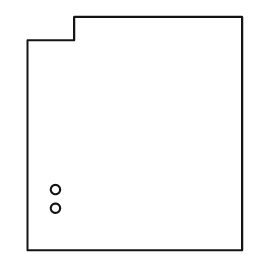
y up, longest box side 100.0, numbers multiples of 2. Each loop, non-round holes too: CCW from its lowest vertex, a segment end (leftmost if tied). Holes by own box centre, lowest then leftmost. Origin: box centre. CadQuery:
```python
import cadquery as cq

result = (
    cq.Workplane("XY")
    .moveTo(-46.0, -50.0)
    .lineTo(46.0, -50.0)
    .lineTo(46.0, 50.0)
    .lineTo(-26.0, 50.0)
    .lineTo(-26.0, 40.0)
    .lineTo(-46.0, 40.0)
    .close()
    .moveTo(-34.0, -32.0)
    .circle(2.0)
    .moveTo(-34.0, -24.0)
    .circle(2.0)
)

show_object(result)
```